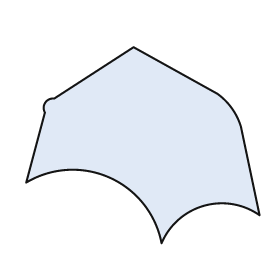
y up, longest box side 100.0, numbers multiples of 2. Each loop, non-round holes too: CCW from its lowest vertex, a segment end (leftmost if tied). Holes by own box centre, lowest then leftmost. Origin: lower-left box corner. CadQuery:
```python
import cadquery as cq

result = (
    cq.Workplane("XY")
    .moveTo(58.0, 0.0)
    .threePointArc((76.0, 16.0), (100.0, 12.0))
    .lineTo(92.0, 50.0)
    .threePointArc((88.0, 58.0), (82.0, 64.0))
    .lineTo(46.0, 84.0)
    .lineTo(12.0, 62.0)
    .threePointArc((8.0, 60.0), (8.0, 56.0))
    .lineTo(0.0, 26.0)
    .threePointArc((36.0, 28.0), (58.0, 0.0))
    .close()
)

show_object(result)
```